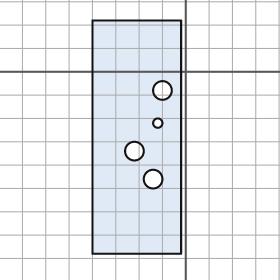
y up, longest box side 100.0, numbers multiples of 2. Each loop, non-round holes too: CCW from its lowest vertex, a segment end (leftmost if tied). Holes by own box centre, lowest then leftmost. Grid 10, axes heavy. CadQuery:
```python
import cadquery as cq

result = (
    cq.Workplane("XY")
    .moveTo(-40.0, -78.0)
    .lineTo(-2.0, -78.0)
    .lineTo(-2.0, 22.0)
    .lineTo(-40.0, 22.0)
    .close()
    .moveTo(-14.0, -46.0)
    .circle(4.0)
    .moveTo(-22.0, -34.0)
    .circle(4.0)
    .moveTo(-12.0, -22.0)
    .circle(2.0)
    .moveTo(-10.0, -8.0)
    .circle(4.0)
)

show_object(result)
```